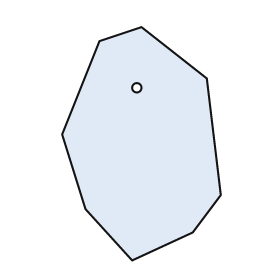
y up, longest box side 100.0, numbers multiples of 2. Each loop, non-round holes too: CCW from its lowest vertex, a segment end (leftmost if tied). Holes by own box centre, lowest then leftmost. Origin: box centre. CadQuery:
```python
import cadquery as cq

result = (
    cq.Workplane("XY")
    .moveTo(-4.0, -50.0)
    .lineTo(22.0, -38.0)
    .lineTo(34.0, -22.0)
    .lineTo(28.0, 28.0)
    .lineTo(0.0, 50.0)
    .lineTo(-18.0, 44.0)
    .lineTo(-34.0, 4.0)
    .lineTo(-24.0, -28.0)
    .close()
    .moveTo(-2.0, 24.0)
    .circle(2.0)
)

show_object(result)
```